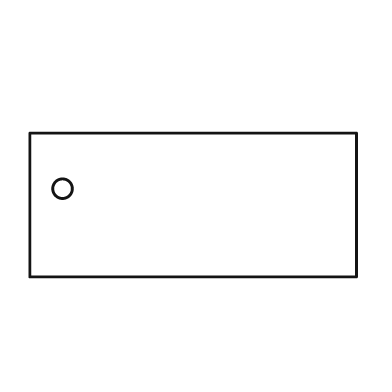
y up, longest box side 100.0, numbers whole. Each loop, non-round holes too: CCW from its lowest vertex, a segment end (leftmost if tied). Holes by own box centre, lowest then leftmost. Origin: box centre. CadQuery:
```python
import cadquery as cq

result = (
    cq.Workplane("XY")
    .moveTo(-50.0, -22.0)
    .lineTo(50.0, -22.0)
    .lineTo(50.0, 22.0)
    .lineTo(-50.0, 22.0)
    .close()
    .moveTo(-40.0, 5.0)
    .circle(3.0)
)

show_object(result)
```